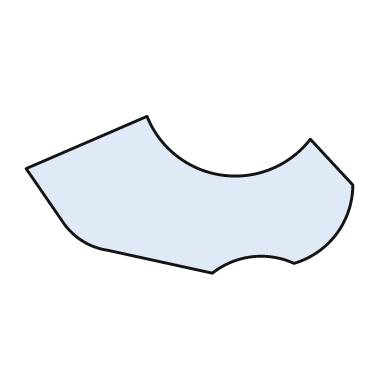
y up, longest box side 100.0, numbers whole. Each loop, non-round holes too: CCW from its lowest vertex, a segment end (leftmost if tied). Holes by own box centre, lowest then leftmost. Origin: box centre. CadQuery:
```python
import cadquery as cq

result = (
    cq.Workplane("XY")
    .moveTo(7.0, -24.0)
    .threePointArc((19.0, -19.0), (32.0, -21.0))
    .threePointArc((45.0, -12.0), (50.0, 3.0))
    .lineTo(37.0, 17.0)
    .threePointArc((10.0, 6.0), (-13.0, 24.0))
    .lineTo(-50.0, 8.0)
    .lineTo(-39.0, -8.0)
    .threePointArc((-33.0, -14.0), (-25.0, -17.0))
    .close()
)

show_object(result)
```